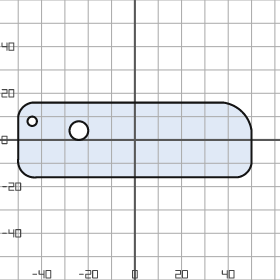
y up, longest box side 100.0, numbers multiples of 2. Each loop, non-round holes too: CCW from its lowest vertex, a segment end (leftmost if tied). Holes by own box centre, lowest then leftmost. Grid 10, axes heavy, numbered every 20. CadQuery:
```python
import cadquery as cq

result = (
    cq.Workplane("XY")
    .moveTo(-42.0, -16.0)
    .lineTo(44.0, -16.0)
    .threePointArc((48.0, -14.0), (50.0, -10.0))
    .lineTo(50.0, 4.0)
    .threePointArc((46.0, 12.0), (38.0, 16.0))
    .lineTo(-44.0, 16.0)
    .threePointArc((-48.0, 14.0), (-50.0, 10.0))
    .lineTo(-50.0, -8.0)
    .threePointArc((-48.0, -14.0), (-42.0, -16.0))
    .close()
    .moveTo(-24.0, 4.0)
    .circle(4.0)
    .moveTo(-44.0, 8.0)
    .circle(2.0)
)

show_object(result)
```